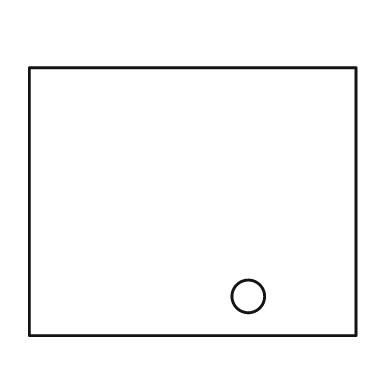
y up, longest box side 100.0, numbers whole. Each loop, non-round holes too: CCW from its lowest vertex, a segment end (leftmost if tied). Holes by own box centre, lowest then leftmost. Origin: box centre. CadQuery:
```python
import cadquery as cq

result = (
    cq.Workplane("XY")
    .moveTo(-50.0, -41.0)
    .lineTo(50.0, -41.0)
    .lineTo(50.0, 41.0)
    .lineTo(-50.0, 41.0)
    .close()
    .moveTo(17.0, -29.0)
    .circle(5.0)
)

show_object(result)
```